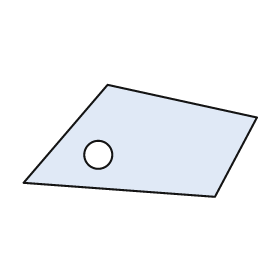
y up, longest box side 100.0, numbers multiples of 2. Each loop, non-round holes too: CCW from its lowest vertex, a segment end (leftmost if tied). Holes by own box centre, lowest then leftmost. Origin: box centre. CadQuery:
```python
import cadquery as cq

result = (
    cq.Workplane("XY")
    .moveTo(32.0, -24.0)
    .lineTo(50.0, 10.0)
    .lineTo(-14.0, 24.0)
    .lineTo(-50.0, -18.0)
    .close()
    .moveTo(-18.0, -6.0)
    .circle(6.0)
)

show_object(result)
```